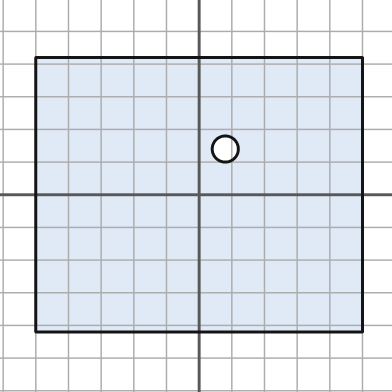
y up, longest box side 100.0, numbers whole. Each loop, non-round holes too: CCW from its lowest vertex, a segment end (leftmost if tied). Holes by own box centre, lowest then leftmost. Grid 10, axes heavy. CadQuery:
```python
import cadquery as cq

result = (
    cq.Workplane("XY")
    .moveTo(-50.0, -42.0)
    .lineTo(50.0, -42.0)
    .lineTo(50.0, 42.0)
    .lineTo(-50.0, 42.0)
    .close()
    .moveTo(8.0, 14.0)
    .circle(4.0)
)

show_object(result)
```